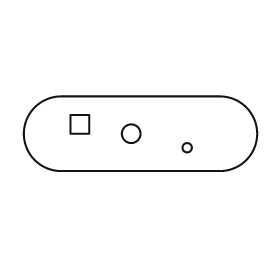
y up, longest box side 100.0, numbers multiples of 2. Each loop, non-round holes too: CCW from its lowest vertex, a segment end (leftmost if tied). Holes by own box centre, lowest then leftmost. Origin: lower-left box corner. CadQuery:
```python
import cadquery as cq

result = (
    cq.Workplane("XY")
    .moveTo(16.0, 0.0)
    .lineTo(84.0, 0.0)
    .threePointArc((100.0, 16.0), (84.0, 32.0))
    .lineTo(16.0, 32.0)
    .threePointArc((0.0, 16.0), (16.0, 0.0))
    .close()
    .moveTo(70.0, 10.0)
    .circle(2.0)
    .moveTo(46.0, 16.0)
    .circle(4.0)
    .moveTo(20.0, 16.0)
    .lineTo(28.0, 16.0)
    .lineTo(28.0, 24.0)
    .lineTo(20.0, 24.0)
    .close()
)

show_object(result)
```